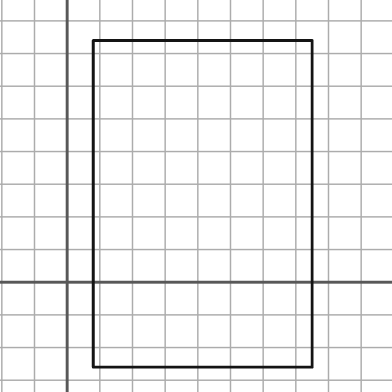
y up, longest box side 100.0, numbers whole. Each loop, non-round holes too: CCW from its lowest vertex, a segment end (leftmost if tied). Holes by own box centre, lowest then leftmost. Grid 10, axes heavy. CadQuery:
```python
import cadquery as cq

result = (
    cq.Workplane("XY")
    .moveTo(8.0, -26.0)
    .lineTo(75.0, -26.0)
    .lineTo(75.0, 74.0)
    .lineTo(8.0, 74.0)
    .close()
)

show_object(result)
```